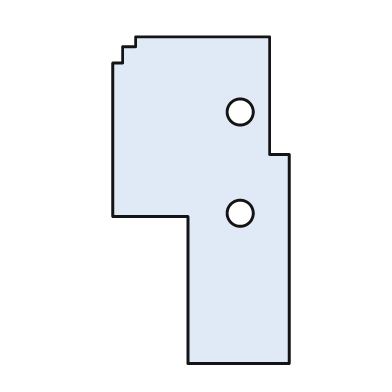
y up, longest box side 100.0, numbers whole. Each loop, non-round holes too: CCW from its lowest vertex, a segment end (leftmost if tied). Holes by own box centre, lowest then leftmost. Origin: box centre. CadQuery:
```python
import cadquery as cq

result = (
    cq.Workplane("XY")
    .moveTo(-4.0, -50.0)
    .lineTo(27.0, -50.0)
    .lineTo(27.0, 14.0)
    .lineTo(21.0, 14.0)
    .lineTo(21.0, 50.0)
    .lineTo(-20.0, 50.0)
    .lineTo(-20.0, 47.0)
    .lineTo(-24.0, 47.0)
    .lineTo(-24.0, 42.0)
    .lineTo(-27.0, 42.0)
    .lineTo(-27.0, -5.0)
    .lineTo(-4.0, -5.0)
    .close()
    .moveTo(12.0, -4.0)
    .circle(4.0)
    .moveTo(12.0, 27.0)
    .circle(4.0)
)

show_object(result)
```